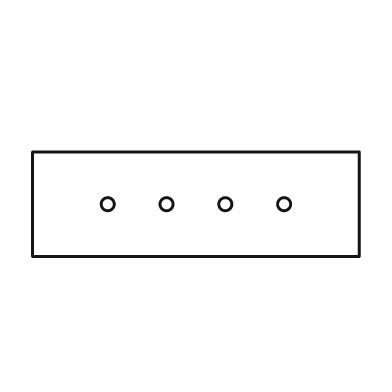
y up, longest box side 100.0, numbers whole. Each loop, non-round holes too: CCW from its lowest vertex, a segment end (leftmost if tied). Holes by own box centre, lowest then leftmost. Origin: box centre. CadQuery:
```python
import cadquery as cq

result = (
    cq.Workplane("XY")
    .moveTo(-50.0, -16.0)
    .lineTo(50.0, -16.0)
    .lineTo(50.0, 16.0)
    .lineTo(-50.0, 16.0)
    .close()
    .moveTo(-27.0, 0.0)
    .circle(2.0)
    .moveTo(-9.0, 0.0)
    .circle(2.0)
    .moveTo(9.0, 0.0)
    .circle(2.0)
    .moveTo(27.0, 0.0)
    .circle(2.0)
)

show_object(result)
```